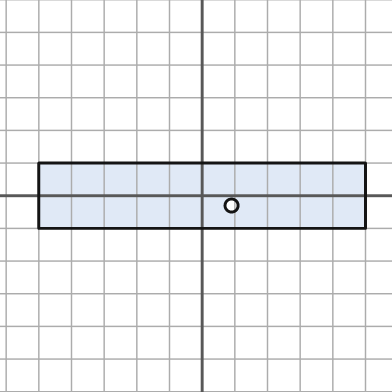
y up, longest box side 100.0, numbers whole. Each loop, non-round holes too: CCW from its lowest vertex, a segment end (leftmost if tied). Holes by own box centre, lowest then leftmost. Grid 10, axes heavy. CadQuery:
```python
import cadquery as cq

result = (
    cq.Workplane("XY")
    .moveTo(-50.0, -10.0)
    .lineTo(50.0, -10.0)
    .lineTo(50.0, 10.0)
    .lineTo(-50.0, 10.0)
    .close()
    .moveTo(9.0, -3.0)
    .circle(2.0)
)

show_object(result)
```